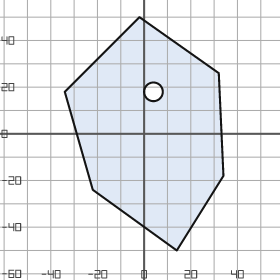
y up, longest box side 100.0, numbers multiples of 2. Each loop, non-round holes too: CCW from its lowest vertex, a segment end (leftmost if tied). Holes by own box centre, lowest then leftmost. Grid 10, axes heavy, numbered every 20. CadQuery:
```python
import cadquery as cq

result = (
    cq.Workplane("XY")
    .moveTo(14.0, -50.0)
    .lineTo(34.0, -18.0)
    .lineTo(32.0, 26.0)
    .lineTo(-2.0, 50.0)
    .lineTo(-34.0, 18.0)
    .lineTo(-22.0, -24.0)
    .close()
    .moveTo(4.0, 18.0)
    .circle(4.0)
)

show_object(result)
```